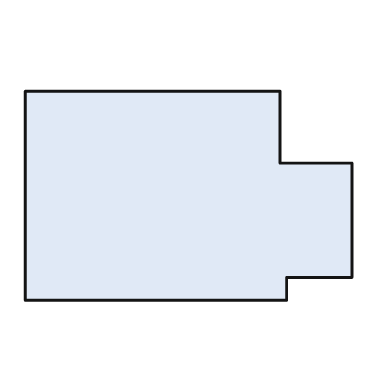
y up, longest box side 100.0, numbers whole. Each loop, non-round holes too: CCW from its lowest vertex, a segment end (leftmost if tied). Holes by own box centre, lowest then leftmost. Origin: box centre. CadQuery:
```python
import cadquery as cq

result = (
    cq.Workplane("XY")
    .moveTo(-50.0, -32.0)
    .lineTo(30.0, -32.0)
    .lineTo(30.0, -25.0)
    .lineTo(50.0, -25.0)
    .lineTo(50.0, 10.0)
    .lineTo(28.0, 10.0)
    .lineTo(28.0, 32.0)
    .lineTo(-50.0, 32.0)
    .close()
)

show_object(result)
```